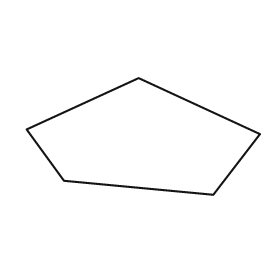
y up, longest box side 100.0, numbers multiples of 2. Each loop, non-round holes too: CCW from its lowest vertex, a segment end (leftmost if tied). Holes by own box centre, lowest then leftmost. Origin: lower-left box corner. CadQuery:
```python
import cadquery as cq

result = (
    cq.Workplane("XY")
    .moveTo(80.0, 0.0)
    .lineTo(100.0, 26.0)
    .lineTo(48.0, 50.0)
    .lineTo(0.0, 28.0)
    .lineTo(16.0, 6.0)
    .close()
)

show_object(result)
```